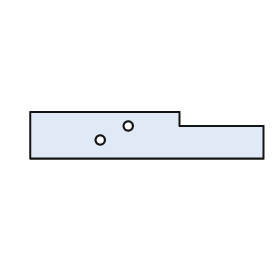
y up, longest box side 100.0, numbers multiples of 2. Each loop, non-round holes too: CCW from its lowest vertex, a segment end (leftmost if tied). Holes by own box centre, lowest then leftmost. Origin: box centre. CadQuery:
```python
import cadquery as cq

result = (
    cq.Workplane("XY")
    .moveTo(-50.0, -10.0)
    .lineTo(50.0, -10.0)
    .lineTo(50.0, 4.0)
    .lineTo(14.0, 4.0)
    .lineTo(14.0, 10.0)
    .lineTo(-50.0, 10.0)
    .close()
    .moveTo(-20.0, -2.0)
    .circle(2.0)
    .moveTo(-8.0, 4.0)
    .circle(2.0)
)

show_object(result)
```